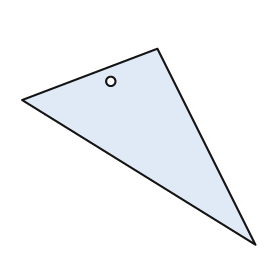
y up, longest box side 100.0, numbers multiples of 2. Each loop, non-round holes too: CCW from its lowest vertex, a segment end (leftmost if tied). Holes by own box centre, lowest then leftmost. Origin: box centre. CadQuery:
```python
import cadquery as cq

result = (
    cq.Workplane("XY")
    .moveTo(50.0, -42.0)
    .lineTo(8.0, 42.0)
    .lineTo(-50.0, 20.0)
    .close()
    .moveTo(-12.0, 28.0)
    .circle(2.0)
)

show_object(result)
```